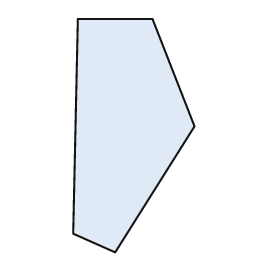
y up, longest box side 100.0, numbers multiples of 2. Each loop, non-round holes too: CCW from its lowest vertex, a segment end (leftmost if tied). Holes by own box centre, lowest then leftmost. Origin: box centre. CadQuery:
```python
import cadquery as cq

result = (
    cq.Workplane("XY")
    .moveTo(-8.0, -50.0)
    .lineTo(26.0, 4.0)
    .lineTo(8.0, 50.0)
    .lineTo(-24.0, 50.0)
    .lineTo(-26.0, -42.0)
    .close()
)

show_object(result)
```